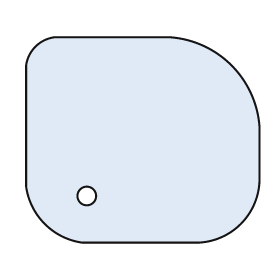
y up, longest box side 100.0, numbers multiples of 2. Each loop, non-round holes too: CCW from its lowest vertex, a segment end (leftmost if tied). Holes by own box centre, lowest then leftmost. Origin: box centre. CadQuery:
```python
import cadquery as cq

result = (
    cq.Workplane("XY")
    .moveTo(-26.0, -44.0)
    .lineTo(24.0, -44.0)
    .threePointArc((42.0, -36.0), (50.0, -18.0))
    .lineTo(50.0, 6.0)
    .threePointArc((38.0, 32.0), (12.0, 44.0))
    .lineTo(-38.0, 44.0)
    .threePointArc((-46.0, 40.0), (-50.0, 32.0))
    .lineTo(-50.0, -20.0)
    .threePointArc((-42.0, -36.0), (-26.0, -44.0))
    .close()
    .moveTo(-24.0, -24.0)
    .circle(4.0)
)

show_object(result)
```